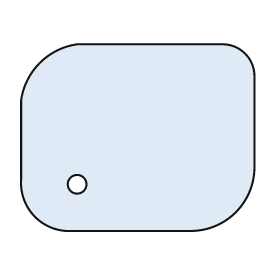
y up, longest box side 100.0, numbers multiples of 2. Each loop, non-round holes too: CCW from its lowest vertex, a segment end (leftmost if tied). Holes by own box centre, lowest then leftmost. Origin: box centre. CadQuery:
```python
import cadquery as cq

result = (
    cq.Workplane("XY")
    .moveTo(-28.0, -40.0)
    .lineTo(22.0, -40.0)
    .threePointArc((42.0, -32.0), (50.0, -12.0))
    .lineTo(50.0, 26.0)
    .threePointArc((46.0, 36.0), (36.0, 40.0))
    .lineTo(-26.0, 40.0)
    .threePointArc((-42.0, 32.0), (-50.0, 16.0))
    .lineTo(-50.0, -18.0)
    .threePointArc((-44.0, -34.0), (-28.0, -40.0))
    .close()
    .moveTo(-26.0, -20.0)
    .circle(4.0)
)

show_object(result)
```